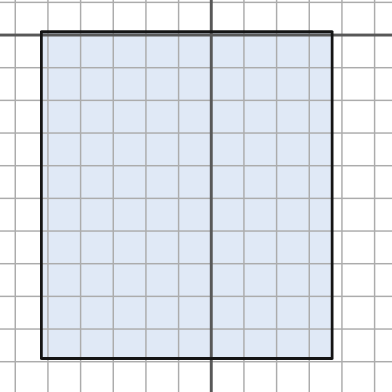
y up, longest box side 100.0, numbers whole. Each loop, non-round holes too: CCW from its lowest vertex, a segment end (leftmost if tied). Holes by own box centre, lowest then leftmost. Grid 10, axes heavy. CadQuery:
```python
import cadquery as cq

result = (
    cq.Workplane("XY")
    .moveTo(-52.0, -99.0)
    .lineTo(37.0, -99.0)
    .lineTo(37.0, 1.0)
    .lineTo(-52.0, 1.0)
    .close()
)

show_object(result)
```